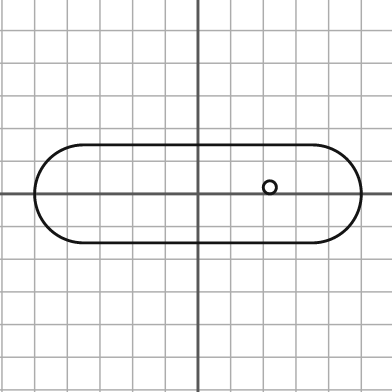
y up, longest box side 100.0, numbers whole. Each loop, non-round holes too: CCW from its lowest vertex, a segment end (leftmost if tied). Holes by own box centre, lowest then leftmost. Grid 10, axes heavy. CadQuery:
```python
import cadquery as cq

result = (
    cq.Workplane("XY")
    .moveTo(-35.0, -15.0)
    .lineTo(35.0, -15.0)
    .threePointArc((50.0, 0.0), (35.0, 15.0))
    .lineTo(-35.0, 15.0)
    .threePointArc((-50.0, 0.0), (-35.0, -15.0))
    .close()
    .moveTo(22.0, 2.0)
    .circle(2.0)
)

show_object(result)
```